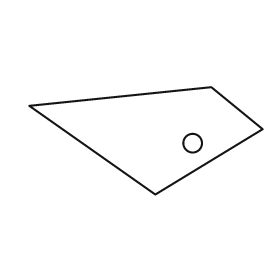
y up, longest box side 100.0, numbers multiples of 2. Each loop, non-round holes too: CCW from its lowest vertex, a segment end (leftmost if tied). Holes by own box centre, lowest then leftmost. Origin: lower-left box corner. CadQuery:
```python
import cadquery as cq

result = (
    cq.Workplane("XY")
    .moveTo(54.0, 0.0)
    .lineTo(100.0, 28.0)
    .lineTo(78.0, 46.0)
    .lineTo(0.0, 38.0)
    .close()
    .moveTo(70.0, 22.0)
    .circle(4.0)
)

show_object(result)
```